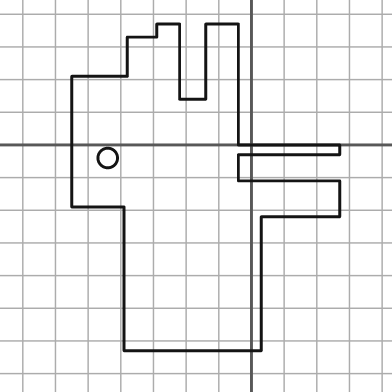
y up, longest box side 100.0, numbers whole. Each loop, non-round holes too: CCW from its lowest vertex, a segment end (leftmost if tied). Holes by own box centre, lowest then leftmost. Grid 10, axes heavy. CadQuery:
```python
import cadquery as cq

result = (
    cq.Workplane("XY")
    .moveTo(-39.0, -63.0)
    .lineTo(3.0, -63.0)
    .lineTo(3.0, -22.0)
    .lineTo(27.0, -22.0)
    .lineTo(27.0, -11.0)
    .lineTo(-4.0, -11.0)
    .lineTo(-4.0, -3.0)
    .lineTo(27.0, -3.0)
    .lineTo(27.0, 0.0)
    .lineTo(-4.0, 0.0)
    .lineTo(-4.0, 37.0)
    .lineTo(-14.0, 37.0)
    .lineTo(-14.0, 14.0)
    .lineTo(-22.0, 14.0)
    .lineTo(-22.0, 37.0)
    .lineTo(-29.0, 37.0)
    .lineTo(-29.0, 33.0)
    .lineTo(-38.0, 33.0)
    .lineTo(-38.0, 21.0)
    .lineTo(-55.0, 21.0)
    .lineTo(-55.0, -19.0)
    .lineTo(-39.0, -19.0)
    .close()
    .moveTo(-44.0, -4.0)
    .circle(3.0)
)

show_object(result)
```